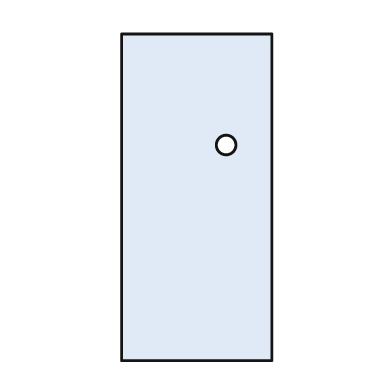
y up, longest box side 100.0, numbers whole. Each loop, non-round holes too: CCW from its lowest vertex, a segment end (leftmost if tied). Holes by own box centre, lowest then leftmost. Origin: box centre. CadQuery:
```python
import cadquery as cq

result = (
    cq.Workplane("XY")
    .moveTo(-23.0, -50.0)
    .lineTo(23.0, -50.0)
    .lineTo(23.0, 50.0)
    .lineTo(-23.0, 50.0)
    .close()
    .moveTo(9.0, 16.0)
    .circle(3.0)
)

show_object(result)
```